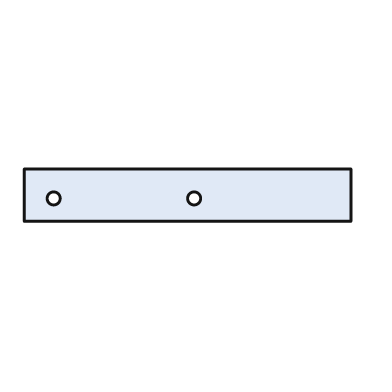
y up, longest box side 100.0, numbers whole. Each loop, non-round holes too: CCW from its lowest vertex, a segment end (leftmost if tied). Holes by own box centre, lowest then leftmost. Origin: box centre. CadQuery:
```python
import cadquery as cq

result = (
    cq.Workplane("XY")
    .moveTo(-50.0, -8.0)
    .lineTo(50.0, -8.0)
    .lineTo(50.0, 8.0)
    .lineTo(-50.0, 8.0)
    .close()
    .moveTo(-41.0, -1.0)
    .circle(2.0)
    .moveTo(2.0, -1.0)
    .circle(2.0)
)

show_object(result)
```